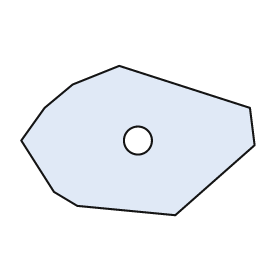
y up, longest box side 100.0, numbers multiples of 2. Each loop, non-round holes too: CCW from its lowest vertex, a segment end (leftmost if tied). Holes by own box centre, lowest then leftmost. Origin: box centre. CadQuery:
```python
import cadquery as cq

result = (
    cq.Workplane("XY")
    .moveTo(16.0, -32.0)
    .lineTo(50.0, -2.0)
    .lineTo(48.0, 14.0)
    .lineTo(-8.0, 32.0)
    .lineTo(-28.0, 24.0)
    .lineTo(-40.0, 14.0)
    .lineTo(-50.0, 0.0)
    .lineTo(-36.0, -22.0)
    .lineTo(-26.0, -28.0)
    .close()
    .moveTo(0.0, 0.0)
    .circle(6.0)
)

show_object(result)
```